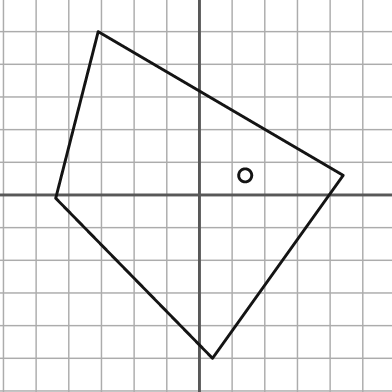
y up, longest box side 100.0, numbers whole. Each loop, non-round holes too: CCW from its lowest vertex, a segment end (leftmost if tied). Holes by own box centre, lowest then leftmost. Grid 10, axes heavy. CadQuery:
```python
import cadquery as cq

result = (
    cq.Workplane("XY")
    .moveTo(4.0, -50.0)
    .lineTo(44.0, 6.0)
    .lineTo(-31.0, 50.0)
    .lineTo(-44.0, -1.0)
    .close()
    .moveTo(14.0, 6.0)
    .circle(2.0)
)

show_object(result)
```